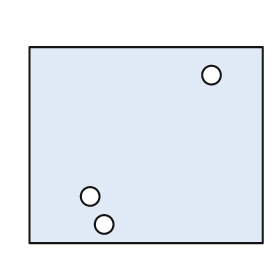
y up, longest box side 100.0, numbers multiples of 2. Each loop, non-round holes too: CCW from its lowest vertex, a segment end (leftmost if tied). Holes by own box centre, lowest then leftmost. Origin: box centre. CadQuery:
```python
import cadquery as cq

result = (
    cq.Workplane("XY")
    .moveTo(-50.0, -42.0)
    .lineTo(50.0, -42.0)
    .lineTo(50.0, 42.0)
    .lineTo(-50.0, 42.0)
    .close()
    .moveTo(-18.0, -34.0)
    .circle(4.0)
    .moveTo(-24.0, -22.0)
    .circle(4.0)
    .moveTo(28.0, 30.0)
    .circle(4.0)
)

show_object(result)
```